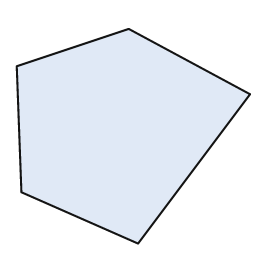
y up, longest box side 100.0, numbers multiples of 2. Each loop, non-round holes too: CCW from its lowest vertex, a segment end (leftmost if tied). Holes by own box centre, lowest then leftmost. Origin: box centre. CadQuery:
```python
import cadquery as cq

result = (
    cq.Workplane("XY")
    .moveTo(2.0, -46.0)
    .lineTo(50.0, 18.0)
    .lineTo(-2.0, 46.0)
    .lineTo(-50.0, 30.0)
    .lineTo(-48.0, -24.0)
    .close()
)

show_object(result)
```